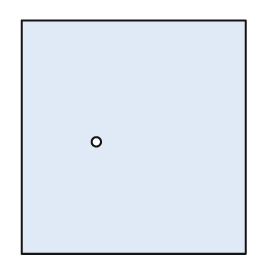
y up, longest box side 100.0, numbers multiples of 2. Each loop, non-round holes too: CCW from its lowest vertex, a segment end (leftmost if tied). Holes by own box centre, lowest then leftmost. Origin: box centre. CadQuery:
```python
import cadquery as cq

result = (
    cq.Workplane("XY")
    .moveTo(-48.0, -50.0)
    .lineTo(48.0, -50.0)
    .lineTo(48.0, 50.0)
    .lineTo(-48.0, 50.0)
    .close()
    .moveTo(-16.0, -2.0)
    .circle(2.0)
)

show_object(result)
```